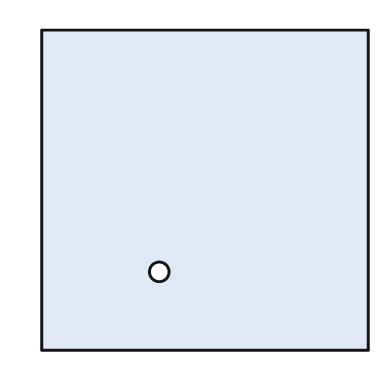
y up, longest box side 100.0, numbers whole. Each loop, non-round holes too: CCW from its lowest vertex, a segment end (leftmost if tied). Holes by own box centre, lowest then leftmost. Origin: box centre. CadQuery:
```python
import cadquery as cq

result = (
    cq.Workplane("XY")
    .moveTo(-50.0, -49.0)
    .lineTo(50.0, -49.0)
    .lineTo(50.0, 49.0)
    .lineTo(-50.0, 49.0)
    .close()
    .moveTo(-14.0, -25.0)
    .circle(3.0)
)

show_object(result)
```